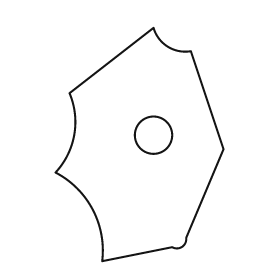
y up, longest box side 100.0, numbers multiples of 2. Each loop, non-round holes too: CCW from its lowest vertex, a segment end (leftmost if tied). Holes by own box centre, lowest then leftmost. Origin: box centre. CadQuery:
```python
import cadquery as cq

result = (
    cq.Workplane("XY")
    .moveTo(-16.0, -50.0)
    .lineTo(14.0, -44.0)
    .threePointArc((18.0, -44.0), (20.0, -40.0))
    .lineTo(36.0, -2.0)
    .lineTo(22.0, 40.0)
    .threePointArc((12.0, 42.0), (6.0, 50.0))
    .lineTo(-30.0, 22.0)
    .threePointArc((-28.0, 4.0), (-36.0, -12.0))
    .threePointArc((-20.0, -28.0), (-16.0, -50.0))
    .close()
    .moveTo(6.0, 4.0)
    .circle(8.0)
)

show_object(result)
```